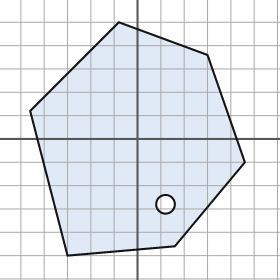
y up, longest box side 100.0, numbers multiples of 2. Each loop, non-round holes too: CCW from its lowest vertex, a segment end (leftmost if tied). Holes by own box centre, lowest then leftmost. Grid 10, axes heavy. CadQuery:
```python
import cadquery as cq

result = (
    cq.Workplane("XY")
    .moveTo(-30.0, -50.0)
    .lineTo(16.0, -46.0)
    .lineTo(46.0, -10.0)
    .lineTo(30.0, 36.0)
    .lineTo(-8.0, 50.0)
    .lineTo(-46.0, 12.0)
    .close()
    .moveTo(12.0, -28.0)
    .circle(4.0)
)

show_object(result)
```